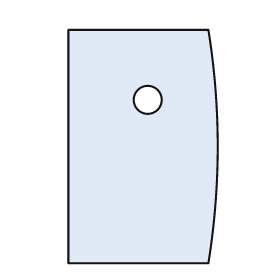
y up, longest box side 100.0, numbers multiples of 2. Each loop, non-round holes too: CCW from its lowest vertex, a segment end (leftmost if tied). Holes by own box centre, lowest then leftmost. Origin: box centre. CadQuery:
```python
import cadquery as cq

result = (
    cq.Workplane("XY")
    .moveTo(-32.0, -50.0)
    .lineTo(28.0, -50.0)
    .threePointArc((32.0, 0.0), (28.0, 50.0))
    .lineTo(-32.0, 50.0)
    .close()
    .moveTo(2.0, 20.0)
    .circle(6.0)
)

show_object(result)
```